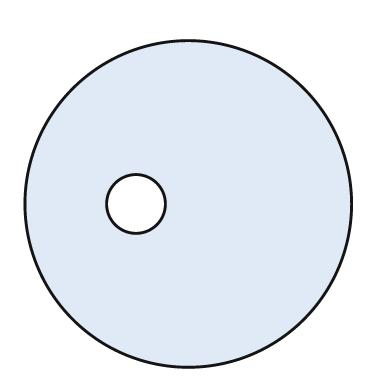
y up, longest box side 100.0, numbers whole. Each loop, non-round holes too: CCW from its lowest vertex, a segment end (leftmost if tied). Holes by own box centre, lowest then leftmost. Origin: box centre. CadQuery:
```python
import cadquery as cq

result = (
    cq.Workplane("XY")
    .moveTo(0.0, 0.0)
    .circle(50.0)
    .moveTo(-16.0, 0.0)
    .circle(9.0)
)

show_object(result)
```